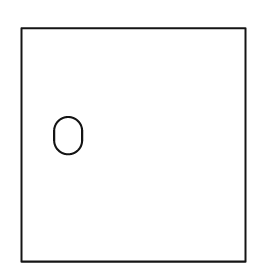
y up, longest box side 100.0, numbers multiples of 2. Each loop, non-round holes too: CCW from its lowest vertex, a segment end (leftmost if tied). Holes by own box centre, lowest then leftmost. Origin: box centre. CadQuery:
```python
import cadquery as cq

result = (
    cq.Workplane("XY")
    .moveTo(-48.0, -50.0)
    .lineTo(48.0, -50.0)
    .lineTo(48.0, 50.0)
    .lineTo(-48.0, 50.0)
    .close()
    .moveTo(-34.0, 2.0)
    .threePointArc((-28.0, -4.0), (-22.0, 2.0))
    .lineTo(-22.0, 6.0)
    .threePointArc((-28.0, 12.0), (-34.0, 6.0))
    .close()
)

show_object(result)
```